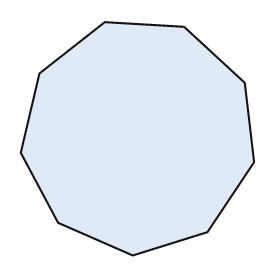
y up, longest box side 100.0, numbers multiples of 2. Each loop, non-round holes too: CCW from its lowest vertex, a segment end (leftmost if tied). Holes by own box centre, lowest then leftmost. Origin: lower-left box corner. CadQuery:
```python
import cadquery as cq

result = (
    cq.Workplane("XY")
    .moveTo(48.0, 0.0)
    .lineTo(80.0, 10.0)
    .lineTo(100.0, 40.0)
    .lineTo(96.0, 74.0)
    .lineTo(70.0, 98.0)
    .lineTo(36.0, 100.0)
    .lineTo(8.0, 78.0)
    .lineTo(0.0, 44.0)
    .lineTo(16.0, 14.0)
    .close()
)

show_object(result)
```